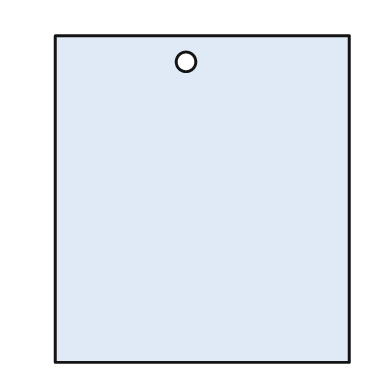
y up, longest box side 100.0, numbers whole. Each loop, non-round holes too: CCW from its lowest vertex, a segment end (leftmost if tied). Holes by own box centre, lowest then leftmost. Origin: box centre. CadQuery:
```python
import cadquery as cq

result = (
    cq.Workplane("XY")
    .moveTo(-45.0, -50.0)
    .lineTo(45.0, -50.0)
    .lineTo(45.0, 50.0)
    .lineTo(-45.0, 50.0)
    .close()
    .moveTo(-5.0, 42.0)
    .circle(3.0)
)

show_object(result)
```